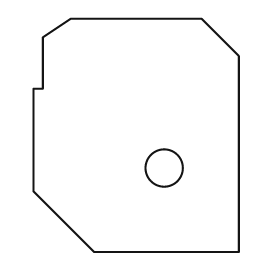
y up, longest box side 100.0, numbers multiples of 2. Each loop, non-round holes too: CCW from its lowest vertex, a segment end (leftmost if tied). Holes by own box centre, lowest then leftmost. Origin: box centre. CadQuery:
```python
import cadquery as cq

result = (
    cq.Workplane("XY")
    .moveTo(-18.0, -50.0)
    .lineTo(44.0, -50.0)
    .lineTo(44.0, 34.0)
    .lineTo(28.0, 50.0)
    .lineTo(-28.0, 50.0)
    .lineTo(-40.0, 42.0)
    .lineTo(-40.0, 20.0)
    .lineTo(-44.0, 20.0)
    .lineTo(-44.0, -24.0)
    .close()
    .moveTo(12.0, -14.0)
    .circle(8.0)
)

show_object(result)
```